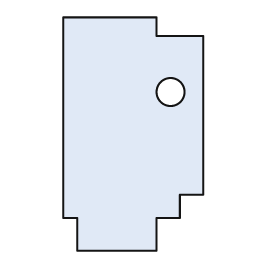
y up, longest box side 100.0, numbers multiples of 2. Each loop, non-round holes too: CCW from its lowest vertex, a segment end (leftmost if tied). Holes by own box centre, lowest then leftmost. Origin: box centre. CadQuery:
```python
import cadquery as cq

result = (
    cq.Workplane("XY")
    .moveTo(-24.0, -50.0)
    .lineTo(10.0, -50.0)
    .lineTo(10.0, -36.0)
    .lineTo(20.0, -36.0)
    .lineTo(20.0, -26.0)
    .lineTo(30.0, -26.0)
    .lineTo(30.0, 42.0)
    .lineTo(10.0, 42.0)
    .lineTo(10.0, 50.0)
    .lineTo(-30.0, 50.0)
    .lineTo(-30.0, -36.0)
    .lineTo(-24.0, -36.0)
    .close()
    .moveTo(16.0, 18.0)
    .circle(6.0)
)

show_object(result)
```